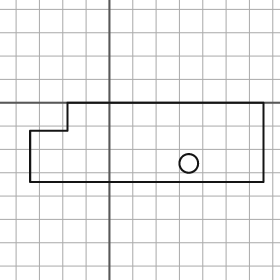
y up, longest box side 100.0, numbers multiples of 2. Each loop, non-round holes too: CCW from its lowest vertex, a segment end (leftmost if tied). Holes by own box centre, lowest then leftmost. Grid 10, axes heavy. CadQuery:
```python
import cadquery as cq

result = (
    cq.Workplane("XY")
    .moveTo(-34.0, -34.0)
    .lineTo(66.0, -34.0)
    .lineTo(66.0, 0.0)
    .lineTo(-18.0, 0.0)
    .lineTo(-18.0, -12.0)
    .lineTo(-34.0, -12.0)
    .close()
    .moveTo(34.0, -26.0)
    .circle(4.0)
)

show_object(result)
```